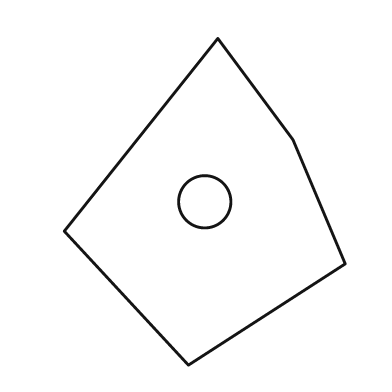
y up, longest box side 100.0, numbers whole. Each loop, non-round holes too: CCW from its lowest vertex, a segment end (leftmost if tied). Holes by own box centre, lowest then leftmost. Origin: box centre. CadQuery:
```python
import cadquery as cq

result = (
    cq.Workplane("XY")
    .moveTo(-5.0, -50.0)
    .lineTo(43.0, -19.0)
    .lineTo(27.0, 19.0)
    .lineTo(4.0, 50.0)
    .lineTo(-43.0, -9.0)
    .close()
    .moveTo(0.0, 0.0)
    .circle(8.0)
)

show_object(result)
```